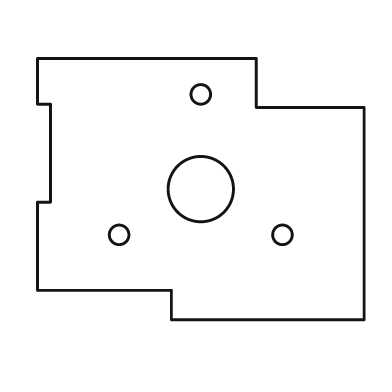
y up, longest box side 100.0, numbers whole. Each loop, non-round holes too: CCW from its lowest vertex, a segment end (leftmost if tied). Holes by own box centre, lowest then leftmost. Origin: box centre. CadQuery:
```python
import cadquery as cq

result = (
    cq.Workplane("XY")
    .moveTo(-9.0, -40.0)
    .lineTo(50.0, -40.0)
    .lineTo(50.0, 25.0)
    .lineTo(17.0, 25.0)
    .lineTo(17.0, 40.0)
    .lineTo(-50.0, 40.0)
    .lineTo(-50.0, 26.0)
    .lineTo(-46.0, 26.0)
    .lineTo(-46.0, -4.0)
    .lineTo(-50.0, -4.0)
    .lineTo(-50.0, -31.0)
    .lineTo(-9.0, -31.0)
    .close()
    .moveTo(-25.0, -14.0)
    .circle(3.0)
    .moveTo(25.0, -14.0)
    .circle(3.0)
    .moveTo(0.0, 0.0)
    .circle(10.0)
    .moveTo(0.0, 29.0)
    .circle(3.0)
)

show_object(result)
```